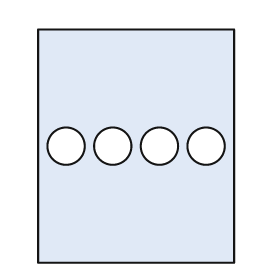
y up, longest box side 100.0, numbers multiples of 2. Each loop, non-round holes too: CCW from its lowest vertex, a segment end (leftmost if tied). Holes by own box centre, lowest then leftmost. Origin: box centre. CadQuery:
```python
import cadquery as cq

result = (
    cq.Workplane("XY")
    .moveTo(-42.0, -50.0)
    .lineTo(42.0, -50.0)
    .lineTo(42.0, 50.0)
    .lineTo(-42.0, 50.0)
    .close()
    .moveTo(-30.0, 0.0)
    .circle(8.0)
    .moveTo(-10.0, 0.0)
    .circle(8.0)
    .moveTo(10.0, 0.0)
    .circle(8.0)
    .moveTo(30.0, 0.0)
    .circle(8.0)
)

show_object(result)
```